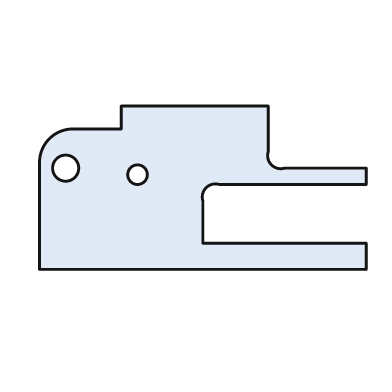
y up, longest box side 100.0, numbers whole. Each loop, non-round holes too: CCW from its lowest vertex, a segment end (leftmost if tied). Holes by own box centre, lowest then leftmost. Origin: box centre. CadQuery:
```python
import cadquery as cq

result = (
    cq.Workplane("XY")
    .moveTo(-50.0, -25.0)
    .lineTo(50.0, -25.0)
    .lineTo(50.0, -17.0)
    .lineTo(0.0, -17.0)
    .lineTo(0.0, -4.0)
    .threePointArc((1.0, 0.0), (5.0, 1.0))
    .lineTo(50.0, 1.0)
    .lineTo(50.0, 6.0)
    .lineTo(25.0, 6.0)
    .threePointArc((21.0, 7.0), (20.0, 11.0))
    .lineTo(20.0, 25.0)
    .lineTo(-25.0, 25.0)
    .lineTo(-25.0, 18.0)
    .lineTo(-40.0, 18.0)
    .threePointArc((-47.0, 15.0), (-50.0, 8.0))
    .close()
    .moveTo(-20.0, 4.0)
    .circle(3.0)
    .moveTo(-42.0, 6.0)
    .circle(4.0)
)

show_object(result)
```